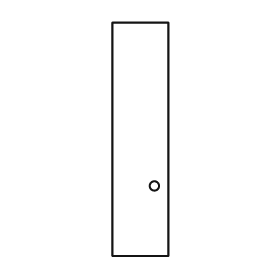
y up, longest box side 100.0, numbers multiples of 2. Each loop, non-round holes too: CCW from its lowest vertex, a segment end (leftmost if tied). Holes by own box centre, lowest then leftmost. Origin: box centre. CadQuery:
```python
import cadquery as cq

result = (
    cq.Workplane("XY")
    .moveTo(-12.0, -50.0)
    .lineTo(12.0, -50.0)
    .lineTo(12.0, 50.0)
    .lineTo(-12.0, 50.0)
    .close()
    .moveTo(6.0, -20.0)
    .circle(2.0)
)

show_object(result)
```